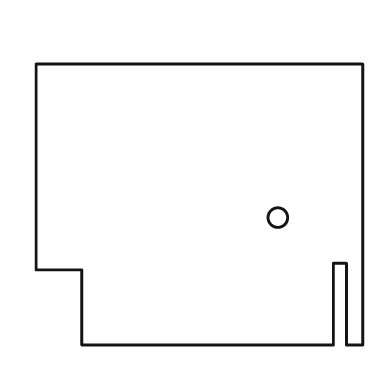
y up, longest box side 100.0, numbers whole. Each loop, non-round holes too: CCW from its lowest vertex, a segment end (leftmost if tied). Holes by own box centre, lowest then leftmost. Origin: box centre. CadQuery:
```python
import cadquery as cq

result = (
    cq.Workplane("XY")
    .moveTo(-36.0, -43.0)
    .lineTo(41.0, -43.0)
    .lineTo(41.0, -18.0)
    .lineTo(45.0, -18.0)
    .lineTo(45.0, -43.0)
    .lineTo(50.0, -43.0)
    .lineTo(50.0, 43.0)
    .lineTo(-50.0, 43.0)
    .lineTo(-50.0, -20.0)
    .lineTo(-36.0, -20.0)
    .close()
    .moveTo(24.0, -4.0)
    .circle(3.0)
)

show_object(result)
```